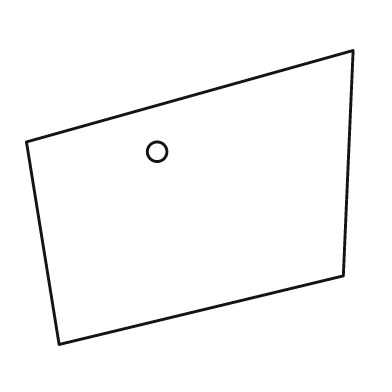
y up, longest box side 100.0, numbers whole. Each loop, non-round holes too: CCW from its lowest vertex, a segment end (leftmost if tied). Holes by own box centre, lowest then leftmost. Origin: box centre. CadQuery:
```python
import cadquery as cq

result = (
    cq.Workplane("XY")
    .moveTo(-40.0, -45.0)
    .lineTo(47.0, -24.0)
    .lineTo(50.0, 45.0)
    .lineTo(-50.0, 17.0)
    .close()
    .moveTo(-10.0, 14.0)
    .circle(3.0)
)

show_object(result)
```